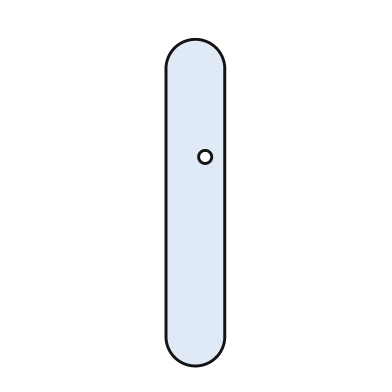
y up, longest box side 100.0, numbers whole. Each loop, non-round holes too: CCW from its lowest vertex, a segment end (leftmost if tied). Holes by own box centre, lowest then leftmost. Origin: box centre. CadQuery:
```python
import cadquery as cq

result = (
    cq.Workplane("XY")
    .moveTo(-9.0, -41.0)
    .threePointArc((0.0, -50.0), (9.0, -41.0))
    .lineTo(9.0, 41.0)
    .threePointArc((0.0, 50.0), (-9.0, 41.0))
    .close()
    .moveTo(3.0, 14.0)
    .circle(2.0)
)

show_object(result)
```